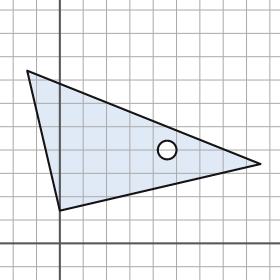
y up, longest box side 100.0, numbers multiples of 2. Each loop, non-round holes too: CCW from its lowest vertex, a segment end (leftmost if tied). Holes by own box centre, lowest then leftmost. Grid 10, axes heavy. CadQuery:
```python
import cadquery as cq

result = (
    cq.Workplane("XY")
    .moveTo(0.0, 14.0)
    .lineTo(86.0, 34.0)
    .lineTo(-14.0, 74.0)
    .close()
    .moveTo(46.0, 40.0)
    .circle(4.0)
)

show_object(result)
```